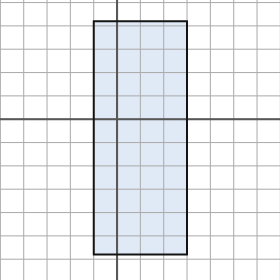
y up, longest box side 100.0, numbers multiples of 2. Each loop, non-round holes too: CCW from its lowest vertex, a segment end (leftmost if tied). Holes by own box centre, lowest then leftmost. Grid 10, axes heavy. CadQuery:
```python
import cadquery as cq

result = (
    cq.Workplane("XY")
    .moveTo(-10.0, -58.0)
    .lineTo(30.0, -58.0)
    .lineTo(30.0, 42.0)
    .lineTo(-10.0, 42.0)
    .close()
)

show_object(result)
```